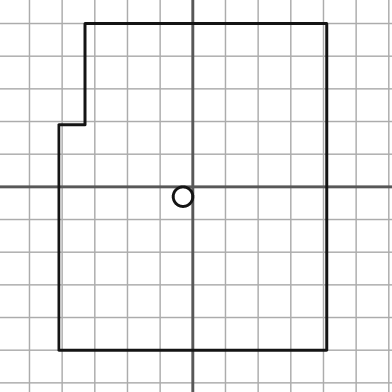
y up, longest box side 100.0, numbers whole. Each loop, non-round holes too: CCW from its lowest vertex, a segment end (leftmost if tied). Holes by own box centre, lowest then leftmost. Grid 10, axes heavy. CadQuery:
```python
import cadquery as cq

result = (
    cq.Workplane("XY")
    .moveTo(-41.0, -50.0)
    .lineTo(41.0, -50.0)
    .lineTo(41.0, 50.0)
    .lineTo(-33.0, 50.0)
    .lineTo(-33.0, 19.0)
    .lineTo(-41.0, 19.0)
    .close()
    .moveTo(-3.0, -3.0)
    .circle(3.0)
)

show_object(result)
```